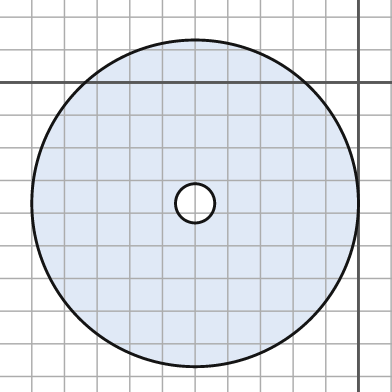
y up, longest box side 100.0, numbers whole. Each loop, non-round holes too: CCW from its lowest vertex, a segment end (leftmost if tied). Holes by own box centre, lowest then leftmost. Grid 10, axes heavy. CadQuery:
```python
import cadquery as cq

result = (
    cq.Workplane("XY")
    .moveTo(-50.0, -37.0)
    .circle(50.0)
    .moveTo(-50.0, -37.0)
    .circle(6.0)
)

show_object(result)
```